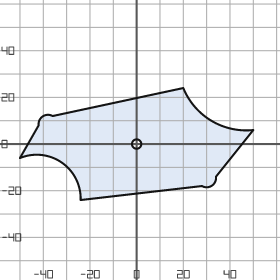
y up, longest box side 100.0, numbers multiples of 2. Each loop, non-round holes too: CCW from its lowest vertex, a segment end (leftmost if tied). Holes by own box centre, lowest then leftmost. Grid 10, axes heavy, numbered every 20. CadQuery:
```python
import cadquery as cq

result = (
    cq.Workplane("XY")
    .moveTo(-24.0, -24.0)
    .lineTo(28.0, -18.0)
    .threePointArc((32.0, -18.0), (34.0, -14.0))
    .lineTo(50.0, 6.0)
    .threePointArc((32.0, 10.0), (20.0, 24.0))
    .lineTo(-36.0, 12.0)
    .threePointArc((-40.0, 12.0), (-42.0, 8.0))
    .lineTo(-50.0, -6.0)
    .threePointArc((-32.0, -8.0), (-24.0, -24.0))
    .close()
    .moveTo(0.0, 0.0)
    .circle(2.0)
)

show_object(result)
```